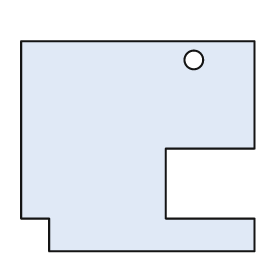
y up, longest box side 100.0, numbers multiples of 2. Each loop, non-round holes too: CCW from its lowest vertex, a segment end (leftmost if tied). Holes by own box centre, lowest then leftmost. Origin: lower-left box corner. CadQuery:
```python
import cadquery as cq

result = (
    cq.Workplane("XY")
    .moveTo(12.0, 0.0)
    .lineTo(100.0, 0.0)
    .lineTo(100.0, 14.0)
    .lineTo(62.0, 14.0)
    .lineTo(62.0, 44.0)
    .lineTo(100.0, 44.0)
    .lineTo(100.0, 90.0)
    .lineTo(0.0, 90.0)
    .lineTo(0.0, 14.0)
    .lineTo(12.0, 14.0)
    .close()
    .moveTo(74.0, 82.0)
    .circle(4.0)
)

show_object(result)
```